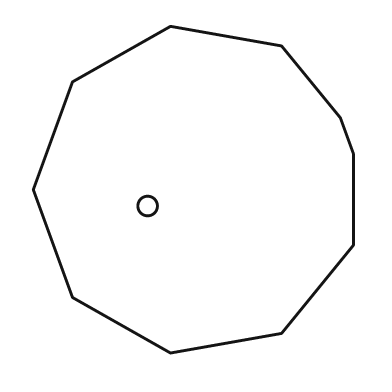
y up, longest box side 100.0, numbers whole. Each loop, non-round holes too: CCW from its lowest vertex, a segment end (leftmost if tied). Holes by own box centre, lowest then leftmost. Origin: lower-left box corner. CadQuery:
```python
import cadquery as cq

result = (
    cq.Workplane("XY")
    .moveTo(42.0, 0.0)
    .lineTo(76.0, 6.0)
    .lineTo(98.0, 33.0)
    .lineTo(98.0, 61.0)
    .lineTo(94.0, 72.0)
    .lineTo(76.0, 94.0)
    .lineTo(42.0, 100.0)
    .lineTo(12.0, 83.0)
    .lineTo(0.0, 50.0)
    .lineTo(12.0, 17.0)
    .close()
    .moveTo(35.0, 45.0)
    .circle(3.0)
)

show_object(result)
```